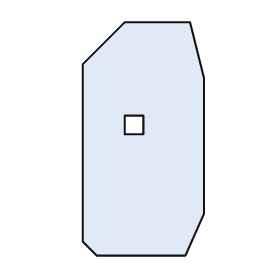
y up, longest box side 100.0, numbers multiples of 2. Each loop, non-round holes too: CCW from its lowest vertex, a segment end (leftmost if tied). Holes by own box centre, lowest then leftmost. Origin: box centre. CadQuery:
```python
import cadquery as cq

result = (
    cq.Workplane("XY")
    .moveTo(-20.0, -50.0)
    .lineTo(18.0, -50.0)
    .lineTo(26.0, -32.0)
    .lineTo(26.0, 26.0)
    .lineTo(20.0, 50.0)
    .lineTo(-8.0, 50.0)
    .lineTo(-26.0, 32.0)
    .lineTo(-26.0, -44.0)
    .close()
    .moveTo(-8.0, 2.0)
    .lineTo(0.0, 2.0)
    .lineTo(0.0, 10.0)
    .lineTo(-8.0, 10.0)
    .close()
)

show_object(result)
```